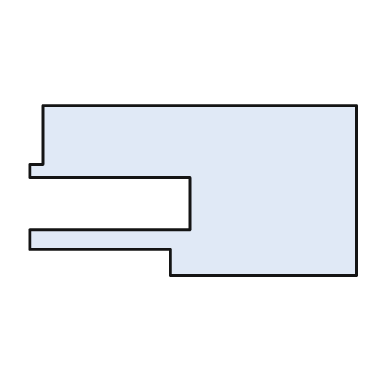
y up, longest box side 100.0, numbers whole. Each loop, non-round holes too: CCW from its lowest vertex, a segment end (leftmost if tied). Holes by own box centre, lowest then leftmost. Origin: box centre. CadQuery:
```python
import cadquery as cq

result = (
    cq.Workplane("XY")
    .moveTo(-7.0, -26.0)
    .lineTo(50.0, -26.0)
    .lineTo(50.0, 26.0)
    .lineTo(-46.0, 26.0)
    .lineTo(-46.0, 8.0)
    .lineTo(-50.0, 8.0)
    .lineTo(-50.0, 4.0)
    .lineTo(-1.0, 4.0)
    .lineTo(-1.0, -12.0)
    .lineTo(-50.0, -12.0)
    .lineTo(-50.0, -18.0)
    .lineTo(-7.0, -18.0)
    .close()
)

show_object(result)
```